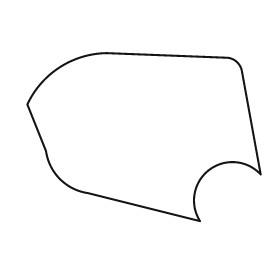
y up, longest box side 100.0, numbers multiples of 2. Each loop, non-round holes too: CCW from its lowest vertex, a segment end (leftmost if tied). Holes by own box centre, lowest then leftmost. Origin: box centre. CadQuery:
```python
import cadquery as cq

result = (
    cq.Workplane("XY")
    .moveTo(24.0, -36.0)
    .threePointArc((28.0, -14.0), (50.0, -16.0))
    .lineTo(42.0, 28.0)
    .threePointArc((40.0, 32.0), (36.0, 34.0))
    .lineTo(-16.0, 36.0)
    .threePointArc((-36.0, 30.0), (-50.0, 14.0))
    .lineTo(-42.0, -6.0)
    .threePointArc((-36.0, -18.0), (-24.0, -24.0))
    .close()
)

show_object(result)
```